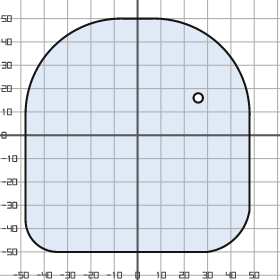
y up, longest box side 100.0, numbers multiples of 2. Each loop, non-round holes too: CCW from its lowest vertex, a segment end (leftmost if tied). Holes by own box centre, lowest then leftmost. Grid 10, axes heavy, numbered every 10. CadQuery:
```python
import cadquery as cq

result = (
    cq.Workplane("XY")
    .moveTo(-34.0, -50.0)
    .lineTo(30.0, -50.0)
    .threePointArc((42.0, -44.0), (48.0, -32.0))
    .lineTo(48.0, 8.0)
    .threePointArc((36.0, 38.0), (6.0, 50.0))
    .lineTo(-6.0, 50.0)
    .threePointArc((-36.0, 38.0), (-48.0, 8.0))
    .lineTo(-48.0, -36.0)
    .threePointArc((-44.0, -46.0), (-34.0, -50.0))
    .close()
    .moveTo(26.0, 16.0)
    .circle(2.0)
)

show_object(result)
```